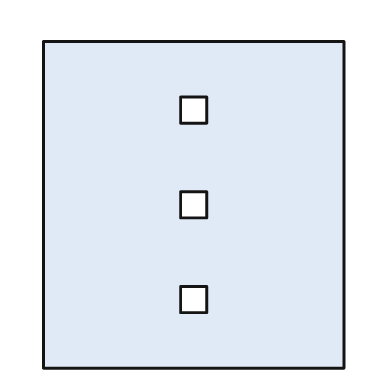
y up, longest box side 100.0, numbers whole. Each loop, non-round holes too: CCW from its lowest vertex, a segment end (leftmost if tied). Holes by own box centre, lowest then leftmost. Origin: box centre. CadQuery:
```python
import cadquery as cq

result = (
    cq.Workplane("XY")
    .moveTo(-46.0, -50.0)
    .lineTo(46.0, -50.0)
    .lineTo(46.0, 50.0)
    .lineTo(-46.0, 50.0)
    .close()
    .moveTo(-4.0, -33.0)
    .lineTo(4.0, -33.0)
    .lineTo(4.0, -25.0)
    .lineTo(-4.0, -25.0)
    .close()
    .moveTo(-4.0, -4.0)
    .lineTo(4.0, -4.0)
    .lineTo(4.0, 4.0)
    .lineTo(-4.0, 4.0)
    .close()
    .moveTo(-4.0, 25.0)
    .lineTo(4.0, 25.0)
    .lineTo(4.0, 33.0)
    .lineTo(-4.0, 33.0)
    .close()
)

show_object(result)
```